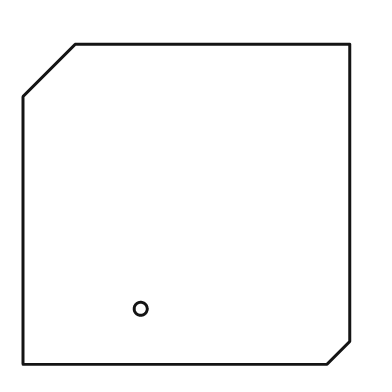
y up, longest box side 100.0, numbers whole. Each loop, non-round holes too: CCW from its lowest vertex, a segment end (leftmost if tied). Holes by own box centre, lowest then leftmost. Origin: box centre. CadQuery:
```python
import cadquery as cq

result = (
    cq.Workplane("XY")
    .moveTo(-50.0, -49.0)
    .lineTo(43.0, -49.0)
    .lineTo(50.0, -42.0)
    .lineTo(50.0, 49.0)
    .lineTo(-34.0, 49.0)
    .lineTo(-50.0, 33.0)
    .close()
    .moveTo(-14.0, -32.0)
    .circle(2.0)
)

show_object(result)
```